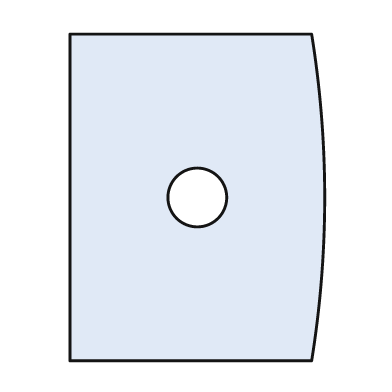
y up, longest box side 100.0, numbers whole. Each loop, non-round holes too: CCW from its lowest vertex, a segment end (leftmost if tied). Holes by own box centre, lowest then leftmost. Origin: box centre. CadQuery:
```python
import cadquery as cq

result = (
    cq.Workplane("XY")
    .moveTo(-39.0, -50.0)
    .lineTo(35.0, -50.0)
    .threePointArc((39.0, 0.0), (35.0, 50.0))
    .lineTo(-39.0, 50.0)
    .close()
    .moveTo(0.0, 0.0)
    .circle(9.0)
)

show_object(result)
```